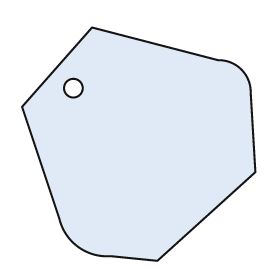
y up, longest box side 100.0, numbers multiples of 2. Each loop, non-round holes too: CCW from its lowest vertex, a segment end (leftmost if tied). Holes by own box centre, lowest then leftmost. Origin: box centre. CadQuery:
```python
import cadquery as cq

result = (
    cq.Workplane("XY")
    .moveTo(8.0, -50.0)
    .lineTo(50.0, -12.0)
    .lineTo(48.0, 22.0)
    .threePointArc((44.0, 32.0), (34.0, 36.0))
    .lineTo(-20.0, 50.0)
    .lineTo(-50.0, 16.0)
    .lineTo(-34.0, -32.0)
    .threePointArc((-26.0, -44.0), (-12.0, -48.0))
    .close()
    .moveTo(-28.0, 24.0)
    .circle(4.0)
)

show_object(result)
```